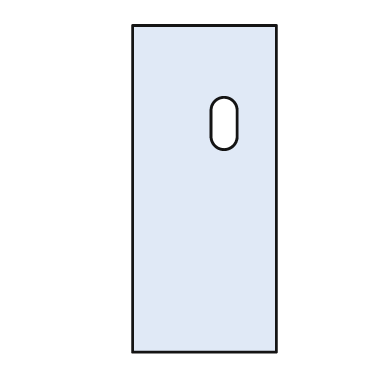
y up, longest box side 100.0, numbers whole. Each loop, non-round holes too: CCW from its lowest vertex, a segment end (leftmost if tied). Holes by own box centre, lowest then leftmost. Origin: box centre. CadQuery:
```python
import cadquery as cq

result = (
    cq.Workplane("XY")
    .moveTo(-22.0, -50.0)
    .lineTo(22.0, -50.0)
    .lineTo(22.0, 50.0)
    .lineTo(-22.0, 50.0)
    .close()
    .moveTo(2.0, 16.0)
    .threePointArc((6.0, 12.0), (10.0, 16.0))
    .lineTo(10.0, 24.0)
    .threePointArc((6.0, 28.0), (2.0, 24.0))
    .close()
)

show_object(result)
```